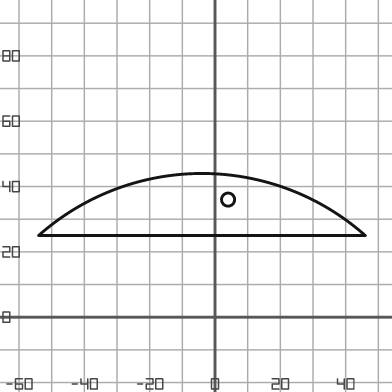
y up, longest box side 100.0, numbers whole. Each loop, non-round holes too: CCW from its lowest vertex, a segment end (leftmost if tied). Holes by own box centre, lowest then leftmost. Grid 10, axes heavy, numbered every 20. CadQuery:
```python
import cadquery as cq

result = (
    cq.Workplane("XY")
    .moveTo(-54.0, 25.0)
    .lineTo(46.0, 25.0)
    .threePointArc((-4.0, 44.0), (-54.0, 25.0))
    .close()
    .moveTo(4.0, 36.0)
    .circle(2.0)
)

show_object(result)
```